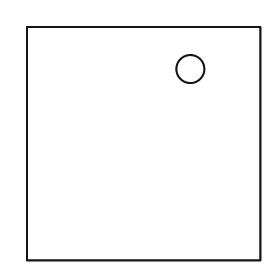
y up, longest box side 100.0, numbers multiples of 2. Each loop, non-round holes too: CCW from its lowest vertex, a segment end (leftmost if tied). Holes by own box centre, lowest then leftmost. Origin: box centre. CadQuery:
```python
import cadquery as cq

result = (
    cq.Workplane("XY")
    .moveTo(-50.0, -50.0)
    .lineTo(50.0, -50.0)
    .lineTo(50.0, 50.0)
    .lineTo(-50.0, 50.0)
    .close()
    .moveTo(20.0, 32.0)
    .circle(6.0)
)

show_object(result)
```